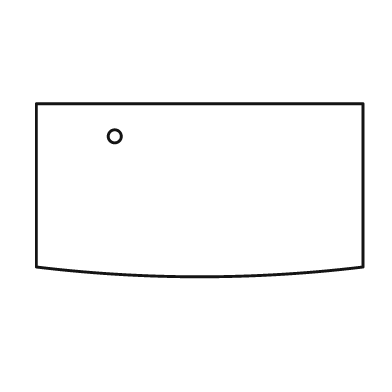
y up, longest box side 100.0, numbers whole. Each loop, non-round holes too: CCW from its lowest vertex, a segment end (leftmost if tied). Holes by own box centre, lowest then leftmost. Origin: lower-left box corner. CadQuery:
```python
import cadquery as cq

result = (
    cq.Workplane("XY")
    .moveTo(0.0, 3.0)
    .threePointArc((50.0, 0.0), (100.0, 3.0))
    .lineTo(100.0, 53.0)
    .lineTo(0.0, 53.0)
    .close()
    .moveTo(24.0, 43.0)
    .circle(2.0)
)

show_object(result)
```